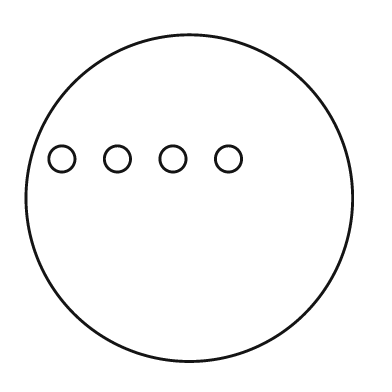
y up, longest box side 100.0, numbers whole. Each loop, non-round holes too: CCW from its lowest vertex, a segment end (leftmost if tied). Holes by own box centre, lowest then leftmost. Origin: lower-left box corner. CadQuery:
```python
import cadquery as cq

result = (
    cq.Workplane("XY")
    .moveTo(50.0, 50.0)
    .circle(50.0)
    .moveTo(11.0, 62.0)
    .circle(4.0)
    .moveTo(28.0, 62.0)
    .circle(4.0)
    .moveTo(45.0, 62.0)
    .circle(4.0)
    .moveTo(62.0, 62.0)
    .circle(4.0)
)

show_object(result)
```